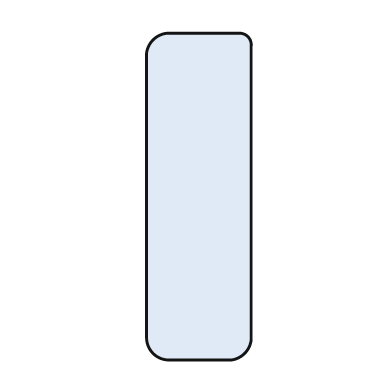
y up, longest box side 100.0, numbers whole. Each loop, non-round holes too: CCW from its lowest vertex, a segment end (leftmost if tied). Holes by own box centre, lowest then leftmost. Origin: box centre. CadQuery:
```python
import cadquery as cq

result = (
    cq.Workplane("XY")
    .moveTo(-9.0, -50.0)
    .lineTo(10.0, -50.0)
    .threePointArc((14.0, -48.0), (16.0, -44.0))
    .lineTo(16.0, 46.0)
    .threePointArc((15.0, 49.0), (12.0, 50.0))
    .lineTo(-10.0, 50.0)
    .threePointArc((-14.0, 48.0), (-16.0, 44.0))
    .lineTo(-16.0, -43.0)
    .threePointArc((-14.0, -48.0), (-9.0, -50.0))
    .close()
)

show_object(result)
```